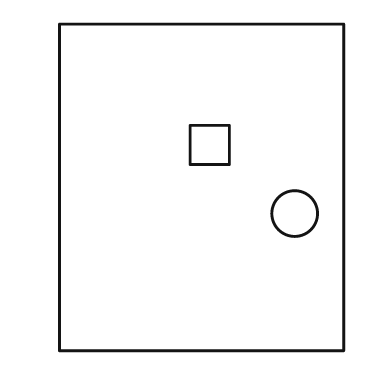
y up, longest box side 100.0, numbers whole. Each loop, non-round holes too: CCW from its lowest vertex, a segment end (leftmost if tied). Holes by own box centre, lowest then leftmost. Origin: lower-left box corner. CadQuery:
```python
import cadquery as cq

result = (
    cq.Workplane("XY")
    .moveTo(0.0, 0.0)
    .lineTo(87.0, 0.0)
    .lineTo(87.0, 100.0)
    .lineTo(0.0, 100.0)
    .close()
    .moveTo(72.0, 42.0)
    .circle(7.0)
    .moveTo(40.0, 57.0)
    .lineTo(52.0, 57.0)
    .lineTo(52.0, 69.0)
    .lineTo(40.0, 69.0)
    .close()
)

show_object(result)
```